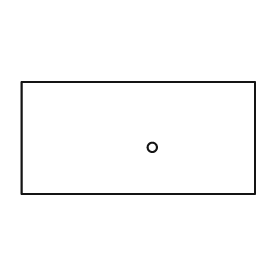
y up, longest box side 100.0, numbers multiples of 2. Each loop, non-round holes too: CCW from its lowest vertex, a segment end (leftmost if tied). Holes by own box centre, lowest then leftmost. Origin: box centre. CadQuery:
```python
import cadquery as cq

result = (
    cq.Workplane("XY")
    .moveTo(-50.0, -24.0)
    .lineTo(50.0, -24.0)
    .lineTo(50.0, 24.0)
    .lineTo(-50.0, 24.0)
    .close()
    .moveTo(6.0, -4.0)
    .circle(2.0)
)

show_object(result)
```